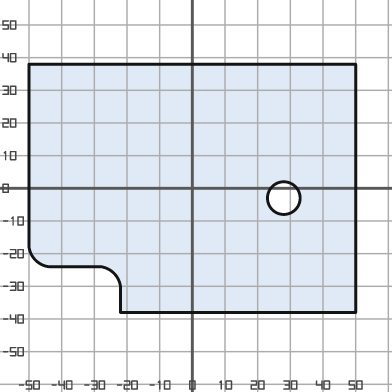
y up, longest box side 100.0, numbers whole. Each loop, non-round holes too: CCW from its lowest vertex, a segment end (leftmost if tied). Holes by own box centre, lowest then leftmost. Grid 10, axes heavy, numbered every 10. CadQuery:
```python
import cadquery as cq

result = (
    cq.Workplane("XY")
    .moveTo(-22.0, -38.0)
    .lineTo(50.0, -38.0)
    .lineTo(50.0, 38.0)
    .lineTo(-50.0, 38.0)
    .lineTo(-50.0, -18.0)
    .threePointArc((-48.0, -22.0), (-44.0, -24.0))
    .lineTo(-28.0, -24.0)
    .threePointArc((-24.0, -26.0), (-22.0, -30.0))
    .close()
    .moveTo(28.0, -3.0)
    .circle(5.0)
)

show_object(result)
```